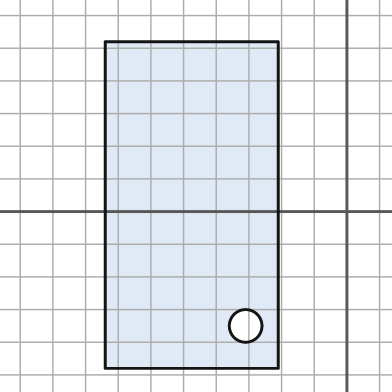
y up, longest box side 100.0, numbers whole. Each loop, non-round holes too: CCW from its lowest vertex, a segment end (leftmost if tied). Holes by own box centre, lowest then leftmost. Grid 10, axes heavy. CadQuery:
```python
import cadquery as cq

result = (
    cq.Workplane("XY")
    .moveTo(-74.0, -48.0)
    .lineTo(-21.0, -48.0)
    .lineTo(-21.0, 52.0)
    .lineTo(-74.0, 52.0)
    .close()
    .moveTo(-31.0, -35.0)
    .circle(5.0)
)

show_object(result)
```